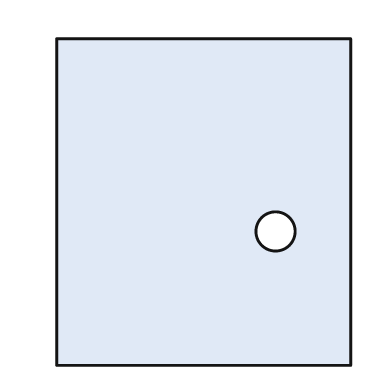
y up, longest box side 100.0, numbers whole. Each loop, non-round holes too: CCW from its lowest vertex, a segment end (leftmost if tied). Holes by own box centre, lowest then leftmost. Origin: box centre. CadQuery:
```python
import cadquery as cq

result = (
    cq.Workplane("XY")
    .moveTo(-45.0, -50.0)
    .lineTo(45.0, -50.0)
    .lineTo(45.0, 50.0)
    .lineTo(-45.0, 50.0)
    .close()
    .moveTo(22.0, -9.0)
    .circle(6.0)
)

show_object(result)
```